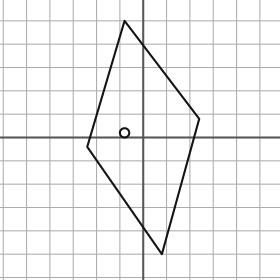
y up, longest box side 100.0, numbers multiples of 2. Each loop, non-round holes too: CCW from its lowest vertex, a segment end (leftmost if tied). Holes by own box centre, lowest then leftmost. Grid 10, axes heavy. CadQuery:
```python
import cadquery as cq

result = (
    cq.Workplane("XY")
    .moveTo(8.0, -50.0)
    .lineTo(24.0, 8.0)
    .lineTo(-8.0, 50.0)
    .lineTo(-24.0, -4.0)
    .close()
    .moveTo(-8.0, 2.0)
    .circle(2.0)
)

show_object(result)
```